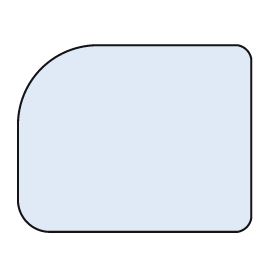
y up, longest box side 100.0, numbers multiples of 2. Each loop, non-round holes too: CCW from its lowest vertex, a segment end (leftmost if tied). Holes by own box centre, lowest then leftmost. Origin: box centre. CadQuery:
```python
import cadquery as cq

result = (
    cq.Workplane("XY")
    .moveTo(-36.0, -40.0)
    .lineTo(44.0, -40.0)
    .threePointArc((48.0, -38.0), (50.0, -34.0))
    .lineTo(50.0, 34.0)
    .threePointArc((48.0, 38.0), (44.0, 40.0))
    .lineTo(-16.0, 40.0)
    .threePointArc((-40.0, 30.0), (-50.0, 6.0))
    .lineTo(-50.0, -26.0)
    .threePointArc((-46.0, -36.0), (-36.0, -40.0))
    .close()
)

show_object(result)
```